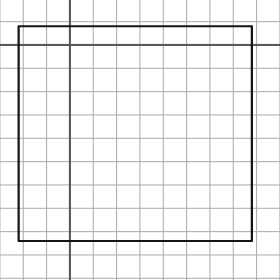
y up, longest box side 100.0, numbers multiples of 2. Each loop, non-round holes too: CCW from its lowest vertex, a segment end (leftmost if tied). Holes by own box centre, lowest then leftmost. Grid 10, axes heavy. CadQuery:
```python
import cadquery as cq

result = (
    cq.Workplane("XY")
    .moveTo(-22.0, -84.0)
    .lineTo(78.0, -84.0)
    .lineTo(78.0, 8.0)
    .lineTo(-22.0, 8.0)
    .close()
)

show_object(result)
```